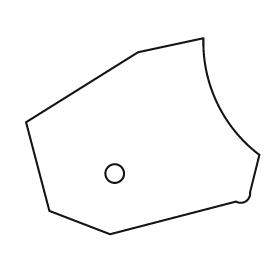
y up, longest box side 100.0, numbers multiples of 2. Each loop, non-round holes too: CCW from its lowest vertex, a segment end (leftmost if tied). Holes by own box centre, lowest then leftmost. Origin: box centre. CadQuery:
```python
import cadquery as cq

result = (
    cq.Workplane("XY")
    .moveTo(-14.0, -42.0)
    .lineTo(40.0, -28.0)
    .threePointArc((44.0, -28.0), (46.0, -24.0))
    .lineTo(50.0, -8.0)
    .threePointArc((32.0, 14.0), (26.0, 42.0))
    .lineTo(-2.0, 36.0)
    .lineTo(-50.0, 6.0)
    .lineTo(-40.0, -32.0)
    .close()
    .moveTo(-12.0, -16.0)
    .circle(4.0)
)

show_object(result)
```